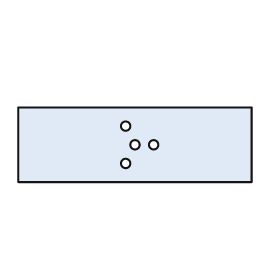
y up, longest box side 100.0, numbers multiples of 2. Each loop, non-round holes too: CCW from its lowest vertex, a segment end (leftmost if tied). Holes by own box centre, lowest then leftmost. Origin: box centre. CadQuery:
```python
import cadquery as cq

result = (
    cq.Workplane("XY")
    .moveTo(-50.0, -16.0)
    .lineTo(50.0, -16.0)
    .lineTo(50.0, 16.0)
    .lineTo(-50.0, 16.0)
    .close()
    .moveTo(-4.0, -8.0)
    .circle(2.0)
    .moveTo(0.0, 0.0)
    .circle(2.0)
    .moveTo(8.0, 0.0)
    .circle(2.0)
    .moveTo(-4.0, 8.0)
    .circle(2.0)
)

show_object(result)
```